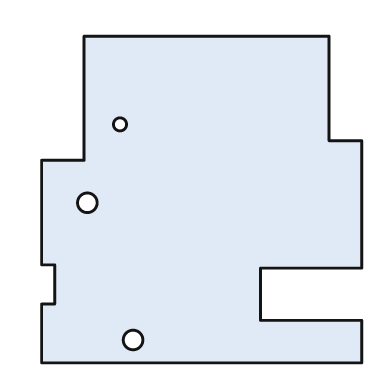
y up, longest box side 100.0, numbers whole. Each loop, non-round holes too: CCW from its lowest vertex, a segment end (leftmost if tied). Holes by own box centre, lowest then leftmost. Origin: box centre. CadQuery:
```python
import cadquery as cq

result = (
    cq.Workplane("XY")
    .moveTo(-49.0, -50.0)
    .lineTo(49.0, -50.0)
    .lineTo(49.0, -37.0)
    .lineTo(18.0, -37.0)
    .lineTo(18.0, -21.0)
    .lineTo(49.0, -21.0)
    .lineTo(49.0, 18.0)
    .lineTo(39.0, 18.0)
    .lineTo(39.0, 50.0)
    .lineTo(-36.0, 50.0)
    .lineTo(-36.0, 12.0)
    .lineTo(-49.0, 12.0)
    .lineTo(-49.0, -20.0)
    .lineTo(-45.0, -20.0)
    .lineTo(-45.0, -32.0)
    .lineTo(-49.0, -32.0)
    .close()
    .moveTo(-21.0, -43.0)
    .circle(3.0)
    .moveTo(-35.0, -1.0)
    .circle(3.0)
    .moveTo(-25.0, 23.0)
    .circle(2.0)
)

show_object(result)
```